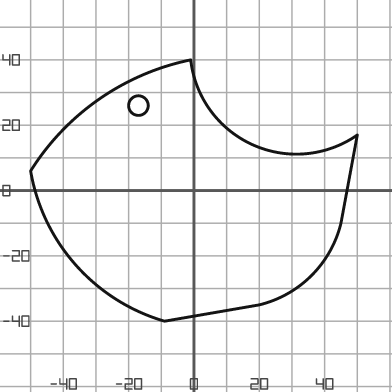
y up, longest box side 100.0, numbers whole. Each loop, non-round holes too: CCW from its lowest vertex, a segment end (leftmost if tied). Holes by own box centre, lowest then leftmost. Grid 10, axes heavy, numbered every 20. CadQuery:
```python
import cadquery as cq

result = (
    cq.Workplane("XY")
    .moveTo(-9.0, -40.0)
    .lineTo(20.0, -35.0)
    .threePointArc((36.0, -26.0), (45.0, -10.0))
    .lineTo(50.0, 17.0)
    .threePointArc((18.0, 14.0), (-1.0, 40.0))
    .threePointArc((-29.0, 28.0), (-50.0, 6.0))
    .threePointArc((-36.0, -23.0), (-9.0, -40.0))
    .close()
    .moveTo(-17.0, 26.0)
    .circle(3.0)
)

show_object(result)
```